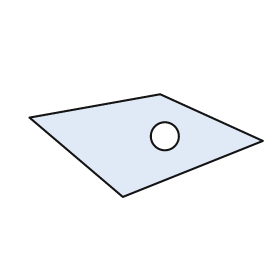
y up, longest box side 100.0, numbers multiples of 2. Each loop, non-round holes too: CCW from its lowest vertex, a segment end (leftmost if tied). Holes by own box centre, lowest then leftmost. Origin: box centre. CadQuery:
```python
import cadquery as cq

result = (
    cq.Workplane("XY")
    .moveTo(-10.0, -22.0)
    .lineTo(50.0, 2.0)
    .lineTo(6.0, 22.0)
    .lineTo(-50.0, 12.0)
    .close()
    .moveTo(8.0, 4.0)
    .circle(6.0)
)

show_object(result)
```